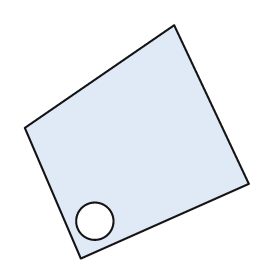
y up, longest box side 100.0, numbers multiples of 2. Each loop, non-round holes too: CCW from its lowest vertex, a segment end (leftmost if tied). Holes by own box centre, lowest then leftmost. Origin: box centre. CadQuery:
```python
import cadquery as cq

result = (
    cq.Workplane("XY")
    .moveTo(-24.0, -50.0)
    .lineTo(48.0, -18.0)
    .lineTo(16.0, 50.0)
    .lineTo(-48.0, 6.0)
    .close()
    .moveTo(-18.0, -34.0)
    .circle(8.0)
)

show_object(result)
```